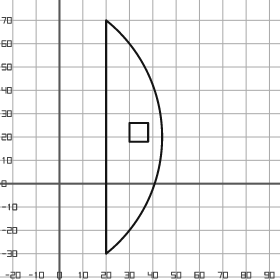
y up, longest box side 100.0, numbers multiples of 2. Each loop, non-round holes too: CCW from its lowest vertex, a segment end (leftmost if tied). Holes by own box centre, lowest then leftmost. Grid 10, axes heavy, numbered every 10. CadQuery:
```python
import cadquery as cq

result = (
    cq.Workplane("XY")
    .moveTo(20.0, -30.0)
    .threePointArc((44.0, 20.0), (20.0, 70.0))
    .close()
    .moveTo(30.0, 18.0)
    .lineTo(38.0, 18.0)
    .lineTo(38.0, 26.0)
    .lineTo(30.0, 26.0)
    .close()
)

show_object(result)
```